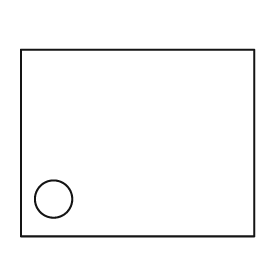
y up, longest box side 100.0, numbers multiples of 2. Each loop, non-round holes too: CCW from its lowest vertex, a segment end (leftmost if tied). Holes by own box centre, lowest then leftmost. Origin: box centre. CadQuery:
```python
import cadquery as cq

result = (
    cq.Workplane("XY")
    .moveTo(-50.0, -40.0)
    .lineTo(50.0, -40.0)
    .lineTo(50.0, 40.0)
    .lineTo(-50.0, 40.0)
    .close()
    .moveTo(-36.0, -24.0)
    .circle(8.0)
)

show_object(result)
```